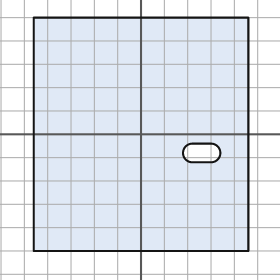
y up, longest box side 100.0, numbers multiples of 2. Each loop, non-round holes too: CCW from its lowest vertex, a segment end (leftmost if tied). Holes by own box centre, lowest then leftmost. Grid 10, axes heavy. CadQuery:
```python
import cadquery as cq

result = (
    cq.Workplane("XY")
    .moveTo(-46.0, -50.0)
    .lineTo(46.0, -50.0)
    .lineTo(46.0, 50.0)
    .lineTo(-46.0, 50.0)
    .close()
    .moveTo(22.0, -12.0)
    .lineTo(30.0, -12.0)
    .threePointArc((34.0, -8.0), (30.0, -4.0))
    .lineTo(22.0, -4.0)
    .threePointArc((18.0, -8.0), (22.0, -12.0))
    .close()
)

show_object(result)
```